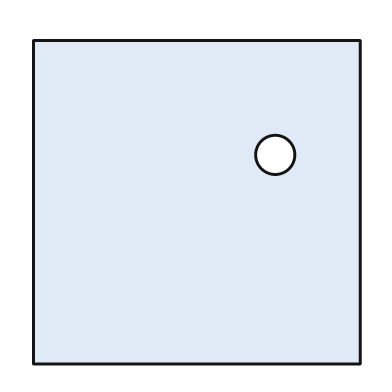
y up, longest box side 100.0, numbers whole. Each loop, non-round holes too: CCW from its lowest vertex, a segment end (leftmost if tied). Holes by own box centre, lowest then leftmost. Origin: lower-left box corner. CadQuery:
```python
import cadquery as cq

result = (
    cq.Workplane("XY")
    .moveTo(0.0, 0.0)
    .lineTo(100.0, 0.0)
    .lineTo(100.0, 99.0)
    .lineTo(0.0, 99.0)
    .close()
    .moveTo(74.0, 64.0)
    .circle(6.0)
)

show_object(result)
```